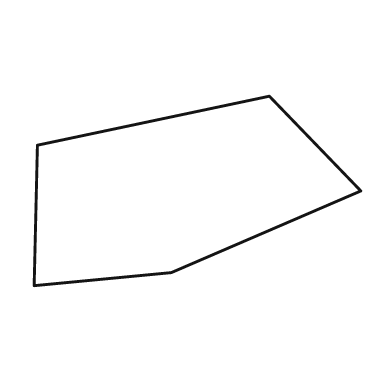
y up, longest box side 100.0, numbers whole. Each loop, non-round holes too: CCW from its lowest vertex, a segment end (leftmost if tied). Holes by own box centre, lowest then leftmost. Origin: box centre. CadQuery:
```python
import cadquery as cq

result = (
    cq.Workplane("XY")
    .moveTo(-50.0, -29.0)
    .lineTo(-8.0, -25.0)
    .lineTo(50.0, 0.0)
    .lineTo(22.0, 29.0)
    .lineTo(-49.0, 14.0)
    .close()
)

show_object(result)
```